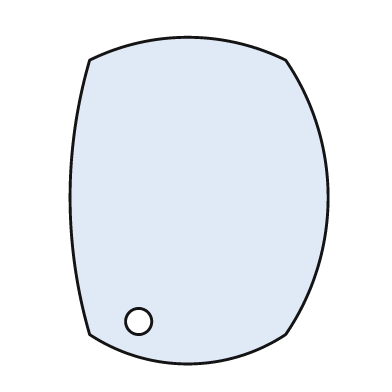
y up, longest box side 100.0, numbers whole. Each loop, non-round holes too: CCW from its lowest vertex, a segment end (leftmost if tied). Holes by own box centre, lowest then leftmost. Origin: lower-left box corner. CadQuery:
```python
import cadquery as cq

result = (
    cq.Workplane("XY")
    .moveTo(6.0, 9.0)
    .threePointArc((36.0, 0.0), (66.0, 9.0))
    .threePointArc((79.0, 51.0), (66.0, 93.0))
    .threePointArc((36.0, 100.0), (6.0, 93.0))
    .threePointArc((0.0, 51.0), (6.0, 9.0))
    .close()
    .moveTo(21.0, 13.0)
    .circle(4.0)
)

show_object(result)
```